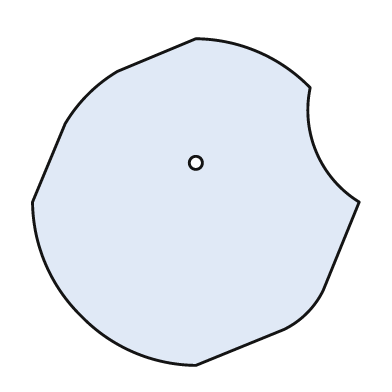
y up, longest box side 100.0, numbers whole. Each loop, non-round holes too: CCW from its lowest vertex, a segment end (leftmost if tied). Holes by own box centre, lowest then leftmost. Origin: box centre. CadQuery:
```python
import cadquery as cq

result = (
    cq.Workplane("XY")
    .moveTo(0.0, -50.0)
    .lineTo(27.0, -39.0)
    .threePointArc((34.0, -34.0), (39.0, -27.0))
    .lineTo(50.0, 0.0)
    .threePointArc((37.0, 15.0), (35.0, 35.0))
    .threePointArc((19.0, 46.0), (0.0, 50.0))
    .lineTo(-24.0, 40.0)
    .threePointArc((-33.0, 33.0), (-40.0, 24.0))
    .lineTo(-50.0, 0.0)
    .threePointArc((-46.0, -19.0), (-35.0, -35.0))
    .threePointArc((-19.0, -46.0), (0.0, -50.0))
    .close()
    .moveTo(0.0, 12.0)
    .circle(2.0)
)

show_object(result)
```